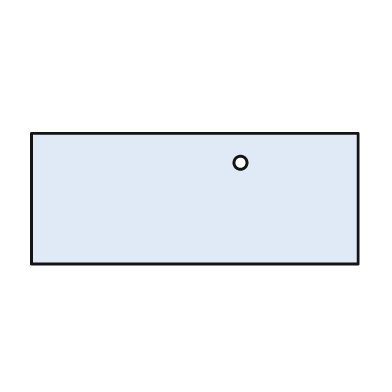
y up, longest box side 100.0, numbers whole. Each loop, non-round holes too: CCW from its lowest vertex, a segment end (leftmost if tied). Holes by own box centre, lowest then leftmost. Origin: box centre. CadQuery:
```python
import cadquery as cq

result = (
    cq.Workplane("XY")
    .moveTo(-50.0, -20.0)
    .lineTo(50.0, -20.0)
    .lineTo(50.0, 20.0)
    .lineTo(-50.0, 20.0)
    .close()
    .moveTo(14.0, 11.0)
    .circle(2.0)
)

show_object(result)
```